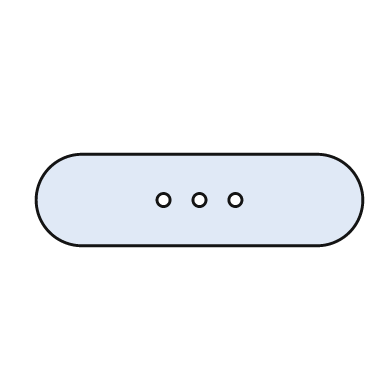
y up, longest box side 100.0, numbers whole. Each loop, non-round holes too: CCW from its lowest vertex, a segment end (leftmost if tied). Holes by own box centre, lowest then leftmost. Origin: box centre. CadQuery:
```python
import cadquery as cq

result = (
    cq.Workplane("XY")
    .moveTo(-36.0, -14.0)
    .lineTo(36.0, -14.0)
    .threePointArc((50.0, 0.0), (36.0, 14.0))
    .lineTo(-36.0, 14.0)
    .threePointArc((-50.0, 0.0), (-36.0, -14.0))
    .close()
    .moveTo(-11.0, 0.0)
    .circle(2.0)
    .moveTo(0.0, 0.0)
    .circle(2.0)
    .moveTo(11.0, 0.0)
    .circle(2.0)
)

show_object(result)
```